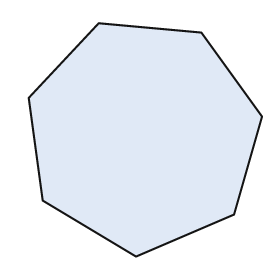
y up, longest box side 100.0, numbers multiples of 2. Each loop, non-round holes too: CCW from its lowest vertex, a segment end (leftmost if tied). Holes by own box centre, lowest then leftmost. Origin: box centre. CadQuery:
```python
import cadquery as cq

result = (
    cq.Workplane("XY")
    .moveTo(-4.0, -50.0)
    .lineTo(38.0, -32.0)
    .lineTo(50.0, 10.0)
    .lineTo(24.0, 46.0)
    .lineTo(-20.0, 50.0)
    .lineTo(-50.0, 18.0)
    .lineTo(-44.0, -26.0)
    .close()
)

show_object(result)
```